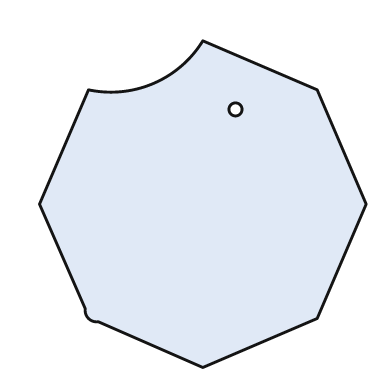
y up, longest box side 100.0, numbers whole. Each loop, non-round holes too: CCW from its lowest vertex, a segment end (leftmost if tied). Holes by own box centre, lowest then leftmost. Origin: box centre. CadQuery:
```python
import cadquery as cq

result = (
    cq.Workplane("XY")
    .moveTo(0.0, -50.0)
    .lineTo(35.0, -35.0)
    .lineTo(50.0, 0.0)
    .lineTo(35.0, 35.0)
    .lineTo(0.0, 50.0)
    .threePointArc((-15.0, 37.0), (-35.0, 35.0))
    .lineTo(-50.0, 0.0)
    .lineTo(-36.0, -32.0)
    .threePointArc((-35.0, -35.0), (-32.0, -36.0))
    .close()
    .moveTo(10.0, 29.0)
    .circle(2.0)
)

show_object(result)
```